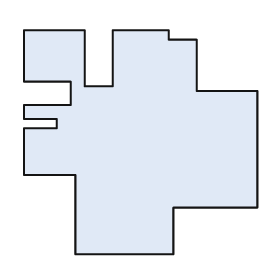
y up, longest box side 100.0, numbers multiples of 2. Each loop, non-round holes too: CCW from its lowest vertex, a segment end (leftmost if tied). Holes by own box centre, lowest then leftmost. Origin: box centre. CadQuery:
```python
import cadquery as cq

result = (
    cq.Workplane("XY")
    .moveTo(-28.0, -48.0)
    .lineTo(14.0, -48.0)
    .lineTo(14.0, -28.0)
    .lineTo(50.0, -28.0)
    .lineTo(50.0, 22.0)
    .lineTo(24.0, 22.0)
    .lineTo(24.0, 44.0)
    .lineTo(12.0, 44.0)
    .lineTo(12.0, 48.0)
    .lineTo(-12.0, 48.0)
    .lineTo(-12.0, 24.0)
    .lineTo(-24.0, 24.0)
    .lineTo(-24.0, 48.0)
    .lineTo(-50.0, 48.0)
    .lineTo(-50.0, 26.0)
    .lineTo(-30.0, 26.0)
    .lineTo(-30.0, 16.0)
    .lineTo(-50.0, 16.0)
    .lineTo(-50.0, 10.0)
    .lineTo(-36.0, 10.0)
    .lineTo(-36.0, 6.0)
    .lineTo(-50.0, 6.0)
    .lineTo(-50.0, -14.0)
    .lineTo(-28.0, -14.0)
    .close()
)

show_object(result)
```